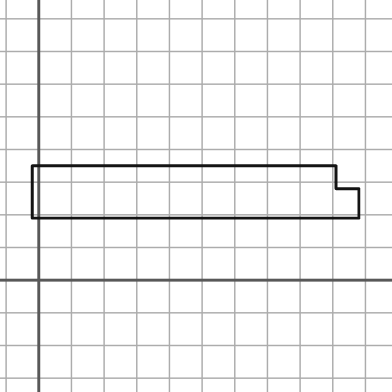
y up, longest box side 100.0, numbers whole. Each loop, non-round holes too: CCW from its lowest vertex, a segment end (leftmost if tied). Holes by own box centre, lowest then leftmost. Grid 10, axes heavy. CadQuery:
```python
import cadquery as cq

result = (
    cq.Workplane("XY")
    .moveTo(-2.0, 19.0)
    .lineTo(98.0, 19.0)
    .lineTo(98.0, 28.0)
    .lineTo(91.0, 28.0)
    .lineTo(91.0, 35.0)
    .lineTo(-2.0, 35.0)
    .close()
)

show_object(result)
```